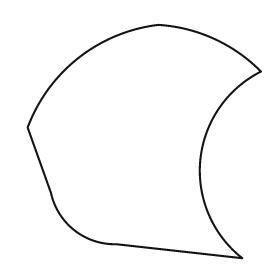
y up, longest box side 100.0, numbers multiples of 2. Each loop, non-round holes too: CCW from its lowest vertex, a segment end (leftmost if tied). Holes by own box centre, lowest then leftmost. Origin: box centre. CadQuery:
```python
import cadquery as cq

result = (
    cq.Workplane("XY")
    .moveTo(42.0, -50.0)
    .threePointArc((24.0, -8.0), (50.0, 30.0))
    .threePointArc((30.0, 44.0), (6.0, 50.0))
    .threePointArc((-28.0, 36.0), (-50.0, 6.0))
    .lineTo(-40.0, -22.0)
    .threePointArc((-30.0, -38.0), (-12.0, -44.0))
    .close()
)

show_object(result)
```